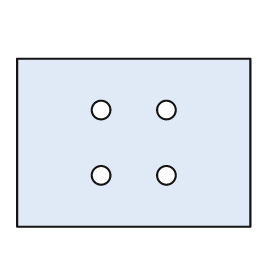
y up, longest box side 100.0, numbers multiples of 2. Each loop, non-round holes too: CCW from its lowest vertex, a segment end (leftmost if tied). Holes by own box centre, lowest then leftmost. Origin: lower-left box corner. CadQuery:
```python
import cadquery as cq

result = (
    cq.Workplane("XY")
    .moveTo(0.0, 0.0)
    .lineTo(100.0, 0.0)
    .lineTo(100.0, 72.0)
    .lineTo(0.0, 72.0)
    .close()
    .moveTo(36.0, 22.0)
    .circle(4.0)
    .moveTo(64.0, 22.0)
    .circle(4.0)
    .moveTo(36.0, 50.0)
    .circle(4.0)
    .moveTo(64.0, 50.0)
    .circle(4.0)
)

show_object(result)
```